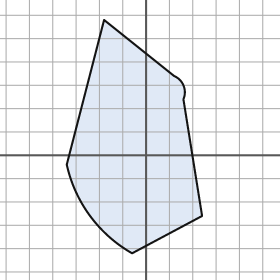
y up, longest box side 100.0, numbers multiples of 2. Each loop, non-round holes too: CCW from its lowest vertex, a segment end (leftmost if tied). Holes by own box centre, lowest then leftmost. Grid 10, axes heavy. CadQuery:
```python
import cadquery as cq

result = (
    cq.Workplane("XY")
    .moveTo(-6.0, -42.0)
    .lineTo(24.0, -26.0)
    .lineTo(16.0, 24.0)
    .threePointArc((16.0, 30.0), (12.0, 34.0))
    .lineTo(-18.0, 58.0)
    .lineTo(-34.0, -4.0)
    .threePointArc((-24.0, -26.0), (-6.0, -42.0))
    .close()
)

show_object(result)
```